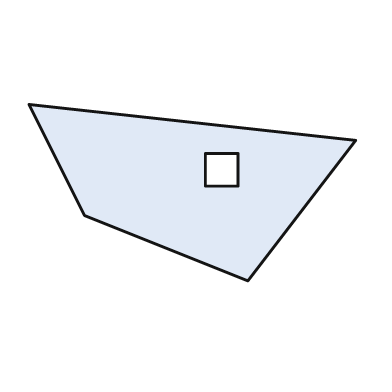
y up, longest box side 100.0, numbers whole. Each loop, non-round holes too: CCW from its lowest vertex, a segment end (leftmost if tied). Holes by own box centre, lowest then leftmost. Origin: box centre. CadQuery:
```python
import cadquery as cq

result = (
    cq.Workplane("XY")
    .moveTo(17.0, -27.0)
    .lineTo(50.0, 16.0)
    .lineTo(-50.0, 27.0)
    .lineTo(-33.0, -7.0)
    .close()
    .moveTo(4.0, 2.0)
    .lineTo(14.0, 2.0)
    .lineTo(14.0, 12.0)
    .lineTo(4.0, 12.0)
    .close()
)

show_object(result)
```